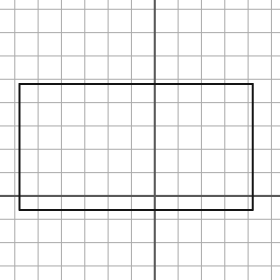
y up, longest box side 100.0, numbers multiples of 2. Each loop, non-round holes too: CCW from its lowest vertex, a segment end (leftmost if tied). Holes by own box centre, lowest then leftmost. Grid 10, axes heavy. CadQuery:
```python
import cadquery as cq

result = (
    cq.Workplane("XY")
    .moveTo(-58.0, -6.0)
    .lineTo(42.0, -6.0)
    .lineTo(42.0, 48.0)
    .lineTo(-58.0, 48.0)
    .close()
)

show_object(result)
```